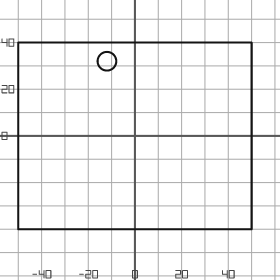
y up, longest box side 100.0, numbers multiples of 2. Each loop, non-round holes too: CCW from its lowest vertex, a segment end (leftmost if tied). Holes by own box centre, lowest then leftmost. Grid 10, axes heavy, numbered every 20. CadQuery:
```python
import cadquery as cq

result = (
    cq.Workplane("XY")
    .moveTo(-50.0, -40.0)
    .lineTo(50.0, -40.0)
    .lineTo(50.0, 40.0)
    .lineTo(-50.0, 40.0)
    .close()
    .moveTo(-12.0, 32.0)
    .circle(4.0)
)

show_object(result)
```